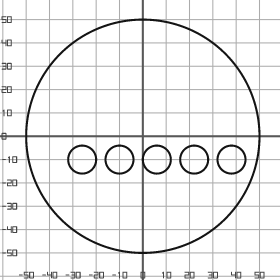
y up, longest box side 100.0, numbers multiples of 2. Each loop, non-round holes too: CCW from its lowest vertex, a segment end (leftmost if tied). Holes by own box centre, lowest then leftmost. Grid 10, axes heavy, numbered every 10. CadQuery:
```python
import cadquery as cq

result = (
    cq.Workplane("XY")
    .moveTo(0.0, 0.0)
    .circle(50.0)
    .moveTo(-26.0, -10.0)
    .circle(6.0)
    .moveTo(-10.0, -10.0)
    .circle(6.0)
    .moveTo(6.0, -10.0)
    .circle(6.0)
    .moveTo(22.0, -10.0)
    .circle(6.0)
    .moveTo(38.0, -10.0)
    .circle(6.0)
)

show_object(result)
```